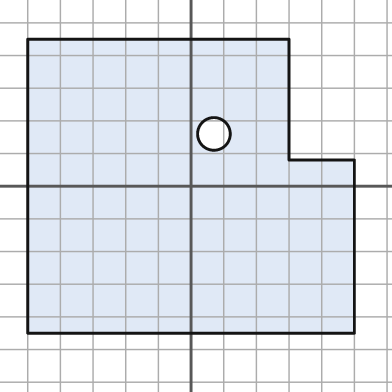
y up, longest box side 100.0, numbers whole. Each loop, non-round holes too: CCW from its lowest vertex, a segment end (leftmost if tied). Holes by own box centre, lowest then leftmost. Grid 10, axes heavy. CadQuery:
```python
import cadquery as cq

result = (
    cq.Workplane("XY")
    .moveTo(-50.0, -45.0)
    .lineTo(50.0, -45.0)
    .lineTo(50.0, 8.0)
    .lineTo(30.0, 8.0)
    .lineTo(30.0, 45.0)
    .lineTo(-50.0, 45.0)
    .close()
    .moveTo(7.0, 16.0)
    .circle(5.0)
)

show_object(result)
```